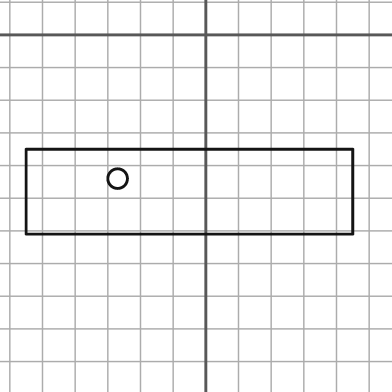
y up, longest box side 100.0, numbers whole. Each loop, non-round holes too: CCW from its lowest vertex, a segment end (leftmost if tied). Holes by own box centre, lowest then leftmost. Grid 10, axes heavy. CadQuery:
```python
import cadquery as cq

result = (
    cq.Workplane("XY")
    .moveTo(-55.0, -61.0)
    .lineTo(45.0, -61.0)
    .lineTo(45.0, -35.0)
    .lineTo(-55.0, -35.0)
    .close()
    .moveTo(-27.0, -44.0)
    .circle(3.0)
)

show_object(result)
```